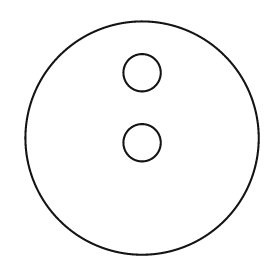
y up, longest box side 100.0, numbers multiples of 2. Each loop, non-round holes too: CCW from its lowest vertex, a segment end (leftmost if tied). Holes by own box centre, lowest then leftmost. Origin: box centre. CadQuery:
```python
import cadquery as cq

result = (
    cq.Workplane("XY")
    .moveTo(0.0, 0.0)
    .circle(50.0)
    .moveTo(0.0, -2.0)
    .circle(8.0)
    .moveTo(0.0, 28.0)
    .circle(8.0)
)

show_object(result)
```